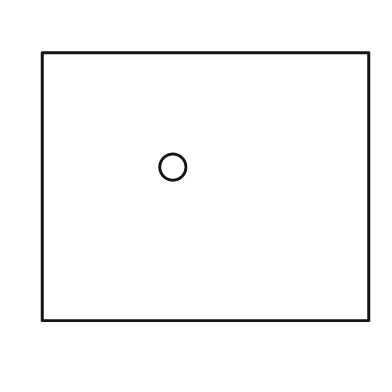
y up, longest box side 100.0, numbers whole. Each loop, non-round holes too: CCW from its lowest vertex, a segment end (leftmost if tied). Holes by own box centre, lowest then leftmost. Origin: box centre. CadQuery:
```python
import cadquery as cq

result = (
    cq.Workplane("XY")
    .moveTo(-50.0, -41.0)
    .lineTo(50.0, -41.0)
    .lineTo(50.0, 41.0)
    .lineTo(-50.0, 41.0)
    .close()
    .moveTo(-10.0, 6.0)
    .circle(4.0)
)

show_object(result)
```